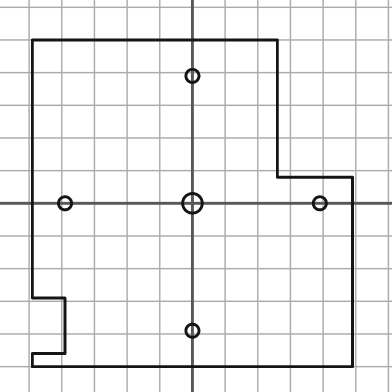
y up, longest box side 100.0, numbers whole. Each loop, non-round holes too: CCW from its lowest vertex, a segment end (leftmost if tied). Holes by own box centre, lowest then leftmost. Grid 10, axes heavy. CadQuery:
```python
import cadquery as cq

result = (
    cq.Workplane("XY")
    .moveTo(-49.0, -50.0)
    .lineTo(49.0, -50.0)
    .lineTo(49.0, 8.0)
    .lineTo(26.0, 8.0)
    .lineTo(26.0, 50.0)
    .lineTo(-49.0, 50.0)
    .lineTo(-49.0, -29.0)
    .lineTo(-39.0, -29.0)
    .lineTo(-39.0, -46.0)
    .lineTo(-49.0, -46.0)
    .close()
    .moveTo(0.0, -39.0)
    .circle(2.0)
    .moveTo(-39.0, 0.0)
    .circle(2.0)
    .moveTo(0.0, 0.0)
    .circle(3.0)
    .moveTo(39.0, 0.0)
    .circle(2.0)
    .moveTo(0.0, 39.0)
    .circle(2.0)
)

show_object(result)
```